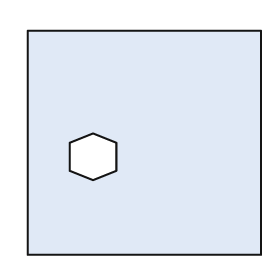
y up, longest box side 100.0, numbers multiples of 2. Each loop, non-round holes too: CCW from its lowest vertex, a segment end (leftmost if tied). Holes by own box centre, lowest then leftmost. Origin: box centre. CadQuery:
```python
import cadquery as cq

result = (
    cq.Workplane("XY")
    .moveTo(-50.0, -48.0)
    .lineTo(50.0, -48.0)
    .lineTo(50.0, 48.0)
    .lineTo(-50.0, 48.0)
    .close()
    .moveTo(-22.0, -16.0)
    .lineTo(-12.0, -12.0)
    .lineTo(-12.0, 0.0)
    .lineTo(-22.0, 4.0)
    .lineTo(-32.0, 0.0)
    .lineTo(-32.0, -12.0)
    .close()
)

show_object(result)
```